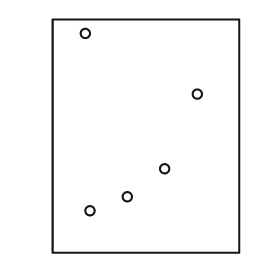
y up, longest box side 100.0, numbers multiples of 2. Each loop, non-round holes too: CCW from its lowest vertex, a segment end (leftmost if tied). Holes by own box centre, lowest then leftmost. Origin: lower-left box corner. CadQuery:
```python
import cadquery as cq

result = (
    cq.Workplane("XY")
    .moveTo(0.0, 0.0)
    .lineTo(80.0, 0.0)
    .lineTo(80.0, 100.0)
    .lineTo(0.0, 100.0)
    .close()
    .moveTo(16.0, 18.0)
    .circle(2.0)
    .moveTo(32.0, 24.0)
    .circle(2.0)
    .moveTo(48.0, 36.0)
    .circle(2.0)
    .moveTo(62.0, 68.0)
    .circle(2.0)
    .moveTo(14.0, 94.0)
    .circle(2.0)
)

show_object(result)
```